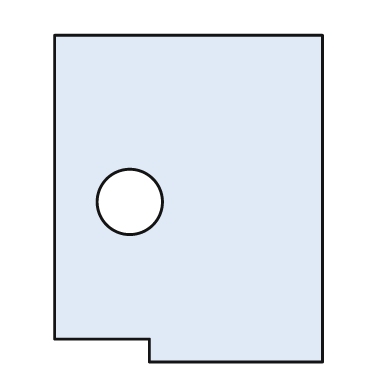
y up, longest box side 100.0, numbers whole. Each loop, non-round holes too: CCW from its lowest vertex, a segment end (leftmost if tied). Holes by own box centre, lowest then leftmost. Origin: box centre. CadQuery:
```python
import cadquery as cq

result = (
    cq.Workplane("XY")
    .moveTo(-12.0, -50.0)
    .lineTo(41.0, -50.0)
    .lineTo(41.0, 50.0)
    .lineTo(-41.0, 50.0)
    .lineTo(-41.0, -43.0)
    .lineTo(-12.0, -43.0)
    .close()
    .moveTo(-18.0, -1.0)
    .circle(10.0)
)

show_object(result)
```